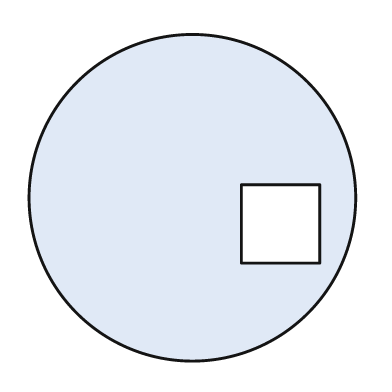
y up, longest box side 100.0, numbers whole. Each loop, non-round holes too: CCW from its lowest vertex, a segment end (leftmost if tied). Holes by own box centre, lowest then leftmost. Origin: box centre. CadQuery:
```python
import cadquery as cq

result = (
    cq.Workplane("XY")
    .moveTo(0.0, 0.0)
    .circle(50.0)
    .moveTo(15.0, -20.0)
    .lineTo(39.0, -20.0)
    .lineTo(39.0, 4.0)
    .lineTo(15.0, 4.0)
    .close()
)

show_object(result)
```